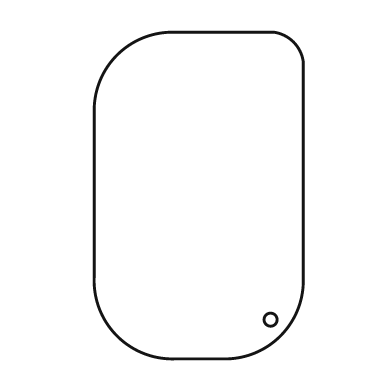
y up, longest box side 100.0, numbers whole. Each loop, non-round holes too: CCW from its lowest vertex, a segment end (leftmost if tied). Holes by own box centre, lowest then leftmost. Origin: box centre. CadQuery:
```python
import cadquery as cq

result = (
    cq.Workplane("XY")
    .moveTo(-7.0, -50.0)
    .lineTo(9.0, -50.0)
    .threePointArc((25.0, -43.0), (32.0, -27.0))
    .lineTo(32.0, 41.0)
    .threePointArc((29.0, 47.0), (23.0, 50.0))
    .lineTo(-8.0, 50.0)
    .threePointArc((-25.0, 43.0), (-32.0, 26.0))
    .lineTo(-32.0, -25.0)
    .threePointArc((-25.0, -43.0), (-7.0, -50.0))
    .close()
    .moveTo(22.0, -38.0)
    .circle(2.0)
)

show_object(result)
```